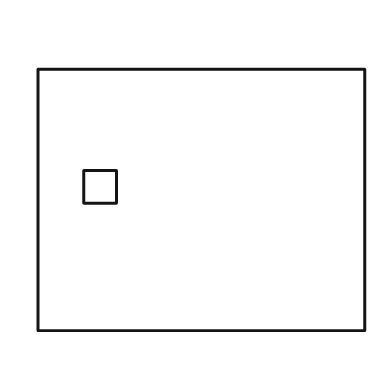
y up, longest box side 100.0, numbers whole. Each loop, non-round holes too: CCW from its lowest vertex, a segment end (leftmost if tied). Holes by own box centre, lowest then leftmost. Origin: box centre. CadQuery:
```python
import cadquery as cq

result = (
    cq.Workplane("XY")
    .moveTo(-50.0, -40.0)
    .lineTo(50.0, -40.0)
    .lineTo(50.0, 40.0)
    .lineTo(-50.0, 40.0)
    .close()
    .moveTo(-36.0, -1.0)
    .lineTo(-26.0, -1.0)
    .lineTo(-26.0, 9.0)
    .lineTo(-36.0, 9.0)
    .close()
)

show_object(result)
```